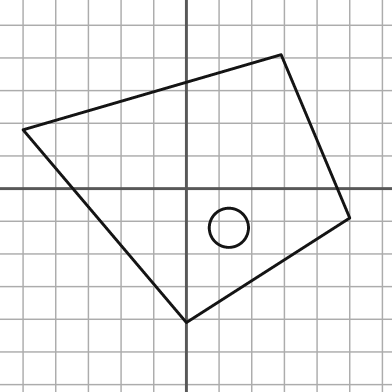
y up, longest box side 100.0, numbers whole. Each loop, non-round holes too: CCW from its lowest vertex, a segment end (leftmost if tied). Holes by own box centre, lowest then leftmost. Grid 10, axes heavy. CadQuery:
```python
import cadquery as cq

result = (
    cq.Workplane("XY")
    .moveTo(0.0, -41.0)
    .lineTo(50.0, -9.0)
    .lineTo(29.0, 41.0)
    .lineTo(-50.0, 18.0)
    .close()
    .moveTo(13.0, -12.0)
    .circle(6.0)
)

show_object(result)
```